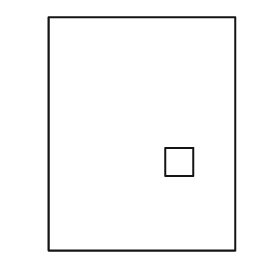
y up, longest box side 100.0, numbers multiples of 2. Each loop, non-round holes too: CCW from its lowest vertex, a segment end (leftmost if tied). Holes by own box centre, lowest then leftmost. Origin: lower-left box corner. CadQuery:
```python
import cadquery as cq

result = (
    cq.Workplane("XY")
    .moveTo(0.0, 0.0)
    .lineTo(80.0, 0.0)
    .lineTo(80.0, 100.0)
    .lineTo(0.0, 100.0)
    .close()
    .moveTo(50.0, 32.0)
    .lineTo(62.0, 32.0)
    .lineTo(62.0, 44.0)
    .lineTo(50.0, 44.0)
    .close()
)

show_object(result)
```